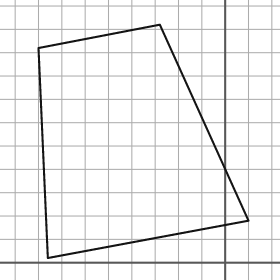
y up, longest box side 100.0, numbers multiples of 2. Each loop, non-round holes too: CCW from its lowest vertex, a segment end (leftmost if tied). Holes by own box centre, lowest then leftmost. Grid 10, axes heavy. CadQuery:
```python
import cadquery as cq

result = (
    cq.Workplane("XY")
    .moveTo(-76.0, 2.0)
    .lineTo(10.0, 18.0)
    .lineTo(-28.0, 102.0)
    .lineTo(-80.0, 92.0)
    .close()
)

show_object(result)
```